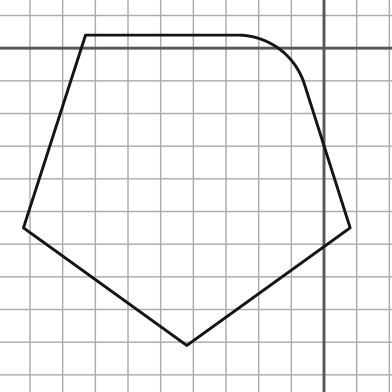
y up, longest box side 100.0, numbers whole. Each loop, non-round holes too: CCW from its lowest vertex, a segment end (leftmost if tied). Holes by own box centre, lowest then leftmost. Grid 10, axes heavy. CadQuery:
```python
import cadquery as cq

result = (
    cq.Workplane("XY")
    .moveTo(-42.0, -91.0)
    .lineTo(8.0, -55.0)
    .lineTo(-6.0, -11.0)
    .threePointArc((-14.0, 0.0), (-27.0, 4.0))
    .lineTo(-73.0, 4.0)
    .lineTo(-92.0, -55.0)
    .close()
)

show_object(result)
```